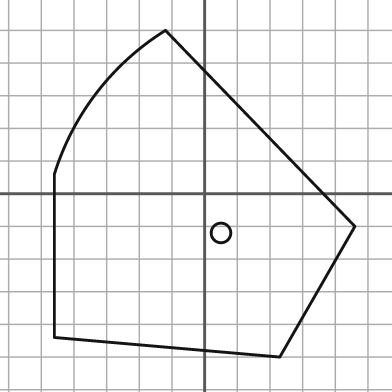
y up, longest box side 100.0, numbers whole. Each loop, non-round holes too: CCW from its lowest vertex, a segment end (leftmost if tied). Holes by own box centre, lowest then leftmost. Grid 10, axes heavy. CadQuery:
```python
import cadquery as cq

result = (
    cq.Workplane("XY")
    .moveTo(23.0, -50.0)
    .lineTo(46.0, -10.0)
    .lineTo(-12.0, 50.0)
    .threePointArc((-33.0, 31.0), (-46.0, 6.0))
    .lineTo(-46.0, -44.0)
    .close()
    .moveTo(5.0, -12.0)
    .circle(3.0)
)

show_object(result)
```